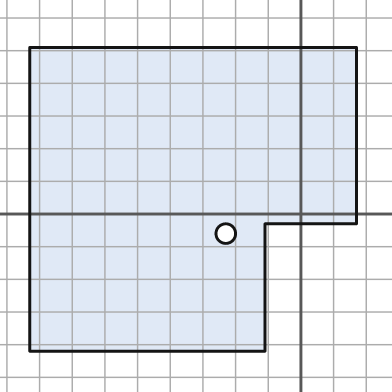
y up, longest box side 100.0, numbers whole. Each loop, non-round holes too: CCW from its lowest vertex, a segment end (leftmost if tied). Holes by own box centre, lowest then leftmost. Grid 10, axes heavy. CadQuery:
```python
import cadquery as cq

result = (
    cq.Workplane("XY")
    .moveTo(-83.0, -42.0)
    .lineTo(-11.0, -42.0)
    .lineTo(-11.0, -3.0)
    .lineTo(17.0, -3.0)
    .lineTo(17.0, 51.0)
    .lineTo(-83.0, 51.0)
    .close()
    .moveTo(-23.0, -6.0)
    .circle(3.0)
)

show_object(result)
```